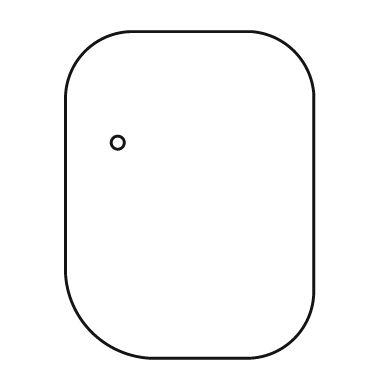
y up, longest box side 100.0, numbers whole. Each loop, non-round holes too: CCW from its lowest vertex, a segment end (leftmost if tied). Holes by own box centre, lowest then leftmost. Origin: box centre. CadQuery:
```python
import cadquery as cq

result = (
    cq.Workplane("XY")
    .moveTo(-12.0, -50.0)
    .lineTo(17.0, -50.0)
    .threePointArc((32.0, -44.0), (38.0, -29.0))
    .lineTo(38.0, 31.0)
    .threePointArc((32.0, 44.0), (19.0, 50.0))
    .lineTo(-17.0, 50.0)
    .threePointArc((-32.0, 44.0), (-38.0, 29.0))
    .lineTo(-38.0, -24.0)
    .threePointArc((-30.0, -42.0), (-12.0, -50.0))
    .close()
    .moveTo(-22.0, 16.0)
    .circle(2.0)
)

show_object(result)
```